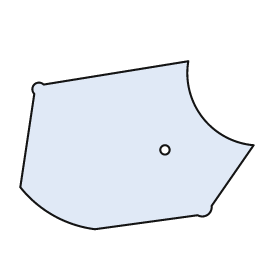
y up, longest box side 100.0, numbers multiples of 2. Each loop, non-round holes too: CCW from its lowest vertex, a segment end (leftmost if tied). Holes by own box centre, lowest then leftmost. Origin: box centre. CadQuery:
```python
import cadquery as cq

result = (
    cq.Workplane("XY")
    .moveTo(-18.0, -36.0)
    .lineTo(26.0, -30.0)
    .threePointArc((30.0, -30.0), (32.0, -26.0))
    .lineTo(50.0, 0.0)
    .threePointArc((28.0, 12.0), (22.0, 36.0))
    .lineTo(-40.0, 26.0)
    .threePointArc((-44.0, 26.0), (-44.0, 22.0))
    .lineTo(-50.0, -18.0)
    .threePointArc((-36.0, -30.0), (-18.0, -36.0))
    .close()
    .moveTo(12.0, -2.0)
    .circle(2.0)
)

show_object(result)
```